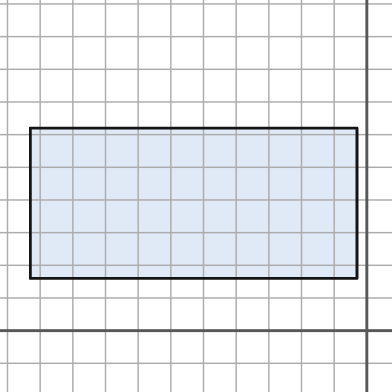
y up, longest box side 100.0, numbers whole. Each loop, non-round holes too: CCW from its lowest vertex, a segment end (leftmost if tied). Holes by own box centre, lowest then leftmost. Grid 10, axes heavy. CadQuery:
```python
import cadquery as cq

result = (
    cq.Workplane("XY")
    .moveTo(-103.0, 16.0)
    .lineTo(-3.0, 16.0)
    .lineTo(-3.0, 62.0)
    .lineTo(-103.0, 62.0)
    .close()
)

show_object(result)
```